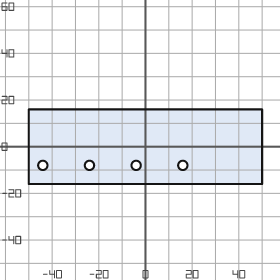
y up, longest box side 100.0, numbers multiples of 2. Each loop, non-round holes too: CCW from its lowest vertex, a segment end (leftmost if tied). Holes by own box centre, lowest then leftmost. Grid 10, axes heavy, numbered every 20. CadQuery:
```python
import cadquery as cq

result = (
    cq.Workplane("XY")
    .moveTo(-50.0, -16.0)
    .lineTo(50.0, -16.0)
    .lineTo(50.0, 16.0)
    .lineTo(-50.0, 16.0)
    .close()
    .moveTo(-44.0, -8.0)
    .circle(2.0)
    .moveTo(-24.0, -8.0)
    .circle(2.0)
    .moveTo(-4.0, -8.0)
    .circle(2.0)
    .moveTo(16.0, -8.0)
    .circle(2.0)
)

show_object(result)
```